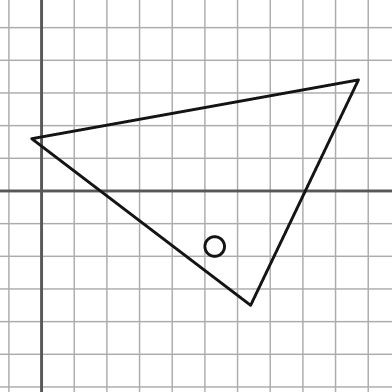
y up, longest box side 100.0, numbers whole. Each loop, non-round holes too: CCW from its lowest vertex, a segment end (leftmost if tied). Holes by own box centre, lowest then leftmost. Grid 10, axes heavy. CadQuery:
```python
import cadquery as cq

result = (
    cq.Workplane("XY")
    .moveTo(64.0, -35.0)
    .lineTo(97.0, 34.0)
    .lineTo(-3.0, 16.0)
    .close()
    .moveTo(53.0, -17.0)
    .circle(3.0)
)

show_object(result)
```